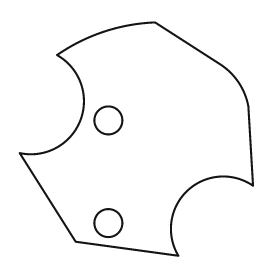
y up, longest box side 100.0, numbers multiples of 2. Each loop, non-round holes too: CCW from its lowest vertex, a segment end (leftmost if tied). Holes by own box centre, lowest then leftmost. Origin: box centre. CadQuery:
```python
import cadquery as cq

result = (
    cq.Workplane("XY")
    .moveTo(18.0, -50.0)
    .threePointArc((22.0, -22.0), (50.0, -20.0))
    .lineTo(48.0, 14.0)
    .threePointArc((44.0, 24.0), (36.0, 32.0))
    .lineTo(8.0, 50.0)
    .threePointArc((-14.0, 46.0), (-34.0, 36.0))
    .threePointArc((-24.0, 8.0), (-50.0, -6.0))
    .lineTo(-26.0, -44.0)
    .close()
    .moveTo(-12.0, -36.0)
    .circle(6.0)
    .moveTo(-12.0, 8.0)
    .circle(6.0)
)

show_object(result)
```